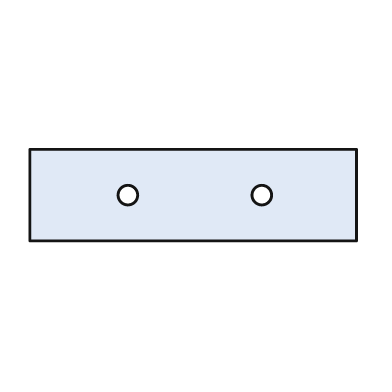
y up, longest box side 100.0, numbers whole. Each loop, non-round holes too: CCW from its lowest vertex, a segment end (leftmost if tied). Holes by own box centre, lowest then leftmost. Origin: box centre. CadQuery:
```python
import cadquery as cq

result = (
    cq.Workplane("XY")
    .moveTo(-50.0, -14.0)
    .lineTo(50.0, -14.0)
    .lineTo(50.0, 14.0)
    .lineTo(-50.0, 14.0)
    .close()
    .moveTo(-20.0, 0.0)
    .circle(3.0)
    .moveTo(21.0, 0.0)
    .circle(3.0)
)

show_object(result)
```